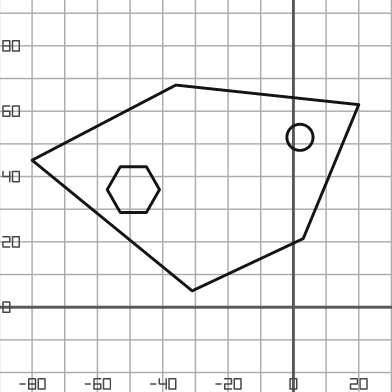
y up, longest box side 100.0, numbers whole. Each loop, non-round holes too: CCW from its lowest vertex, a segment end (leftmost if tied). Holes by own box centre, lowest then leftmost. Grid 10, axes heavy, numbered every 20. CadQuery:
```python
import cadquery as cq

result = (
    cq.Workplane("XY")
    .moveTo(-31.0, 5.0)
    .lineTo(3.0, 21.0)
    .lineTo(20.0, 62.0)
    .lineTo(-36.0, 68.0)
    .lineTo(-80.0, 45.0)
    .close()
    .moveTo(-53.0, 29.0)
    .lineTo(-45.0, 29.0)
    .lineTo(-41.0, 36.0)
    .lineTo(-45.0, 43.0)
    .lineTo(-53.0, 43.0)
    .lineTo(-57.0, 36.0)
    .close()
    .moveTo(2.0, 52.0)
    .circle(4.0)
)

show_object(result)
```